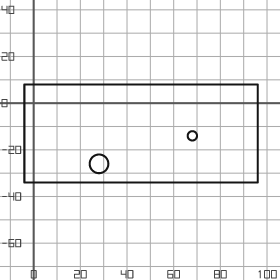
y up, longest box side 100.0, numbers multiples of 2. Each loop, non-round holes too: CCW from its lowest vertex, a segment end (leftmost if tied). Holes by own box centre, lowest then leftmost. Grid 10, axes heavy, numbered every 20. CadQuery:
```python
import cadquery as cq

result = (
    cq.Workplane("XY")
    .moveTo(-4.0, -34.0)
    .lineTo(96.0, -34.0)
    .lineTo(96.0, 8.0)
    .lineTo(-4.0, 8.0)
    .close()
    .moveTo(28.0, -26.0)
    .circle(4.0)
    .moveTo(68.0, -14.0)
    .circle(2.0)
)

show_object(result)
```